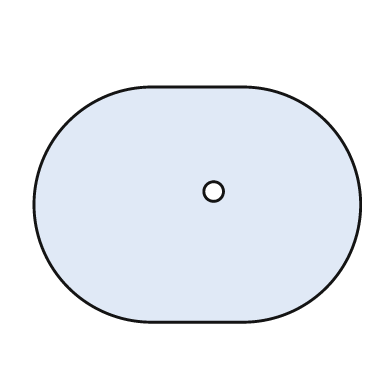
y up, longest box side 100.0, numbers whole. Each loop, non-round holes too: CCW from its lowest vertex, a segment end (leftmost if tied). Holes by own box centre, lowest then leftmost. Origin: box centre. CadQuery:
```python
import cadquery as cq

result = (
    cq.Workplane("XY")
    .moveTo(-14.0, -36.0)
    .lineTo(14.0, -36.0)
    .threePointArc((50.0, 0.0), (14.0, 36.0))
    .lineTo(-14.0, 36.0)
    .threePointArc((-50.0, 0.0), (-14.0, -36.0))
    .close()
    .moveTo(5.0, 4.0)
    .circle(3.0)
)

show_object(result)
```